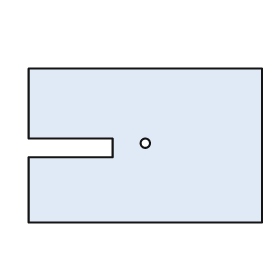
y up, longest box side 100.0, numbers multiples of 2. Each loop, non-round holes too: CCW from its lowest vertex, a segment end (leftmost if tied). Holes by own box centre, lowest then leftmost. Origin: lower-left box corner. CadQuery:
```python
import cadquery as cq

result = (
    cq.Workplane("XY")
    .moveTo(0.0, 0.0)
    .lineTo(100.0, 0.0)
    .lineTo(100.0, 66.0)
    .lineTo(0.0, 66.0)
    .lineTo(0.0, 36.0)
    .lineTo(36.0, 36.0)
    .lineTo(36.0, 28.0)
    .lineTo(0.0, 28.0)
    .close()
    .moveTo(50.0, 34.0)
    .circle(2.0)
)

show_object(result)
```